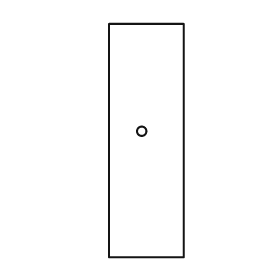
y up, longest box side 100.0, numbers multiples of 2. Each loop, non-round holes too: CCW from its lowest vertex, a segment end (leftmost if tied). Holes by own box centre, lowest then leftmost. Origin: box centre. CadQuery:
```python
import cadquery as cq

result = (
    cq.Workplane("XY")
    .moveTo(-16.0, -50.0)
    .lineTo(16.0, -50.0)
    .lineTo(16.0, 50.0)
    .lineTo(-16.0, 50.0)
    .close()
    .moveTo(-2.0, 4.0)
    .circle(2.0)
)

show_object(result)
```